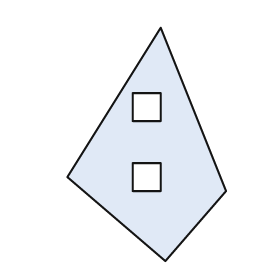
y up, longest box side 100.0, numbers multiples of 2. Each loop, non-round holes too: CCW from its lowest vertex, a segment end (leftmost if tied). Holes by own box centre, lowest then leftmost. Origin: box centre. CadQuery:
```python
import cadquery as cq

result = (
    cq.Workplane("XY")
    .moveTo(8.0, -50.0)
    .lineTo(34.0, -20.0)
    .lineTo(6.0, 50.0)
    .lineTo(-34.0, -14.0)
    .close()
    .moveTo(-6.0, -20.0)
    .lineTo(6.0, -20.0)
    .lineTo(6.0, -8.0)
    .lineTo(-6.0, -8.0)
    .close()
    .moveTo(-6.0, 10.0)
    .lineTo(6.0, 10.0)
    .lineTo(6.0, 22.0)
    .lineTo(-6.0, 22.0)
    .close()
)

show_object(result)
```